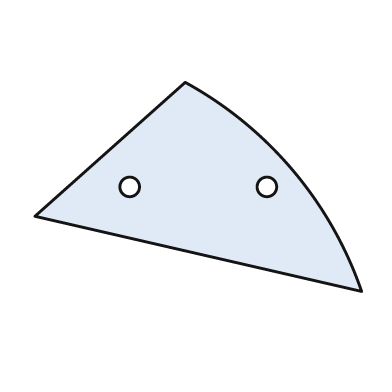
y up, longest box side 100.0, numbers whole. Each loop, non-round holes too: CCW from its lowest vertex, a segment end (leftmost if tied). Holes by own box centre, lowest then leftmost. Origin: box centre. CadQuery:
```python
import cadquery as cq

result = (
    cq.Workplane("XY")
    .moveTo(50.0, -32.0)
    .threePointArc((29.0, 5.0), (-4.0, 32.0))
    .lineTo(-50.0, -9.0)
    .close()
    .moveTo(-21.0, 0.0)
    .circle(3.0)
    .moveTo(21.0, 0.0)
    .circle(3.0)
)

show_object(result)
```